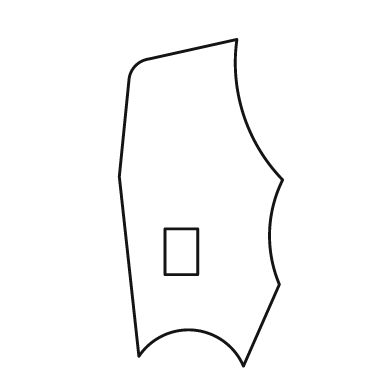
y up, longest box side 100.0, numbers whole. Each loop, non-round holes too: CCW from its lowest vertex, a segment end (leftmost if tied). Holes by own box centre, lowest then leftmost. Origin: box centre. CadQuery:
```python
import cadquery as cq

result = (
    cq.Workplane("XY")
    .moveTo(13.0, -50.0)
    .lineTo(24.0, -25.0)
    .threePointArc((21.0, -9.0), (25.0, 7.0))
    .threePointArc((13.0, 27.0), (11.0, 50.0))
    .lineTo(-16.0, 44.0)
    .threePointArc((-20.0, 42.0), (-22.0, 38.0))
    .lineTo(-25.0, 8.0)
    .lineTo(-19.0, -47.0)
    .threePointArc((-2.0, -39.0), (13.0, -50.0))
    .close()
    .moveTo(-11.0, -22.0)
    .lineTo(-1.0, -22.0)
    .lineTo(-1.0, -8.0)
    .lineTo(-11.0, -8.0)
    .close()
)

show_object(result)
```